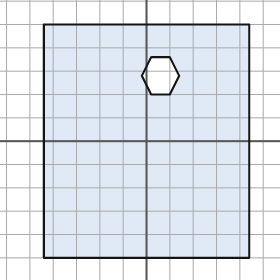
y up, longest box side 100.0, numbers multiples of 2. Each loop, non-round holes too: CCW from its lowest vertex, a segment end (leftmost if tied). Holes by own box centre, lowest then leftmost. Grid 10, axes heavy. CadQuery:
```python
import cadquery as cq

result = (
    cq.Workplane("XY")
    .moveTo(-44.0, -50.0)
    .lineTo(44.0, -50.0)
    .lineTo(44.0, 50.0)
    .lineTo(-44.0, 50.0)
    .close()
    .moveTo(2.0, 20.0)
    .lineTo(10.0, 20.0)
    .lineTo(14.0, 28.0)
    .lineTo(10.0, 36.0)
    .lineTo(2.0, 36.0)
    .lineTo(-2.0, 28.0)
    .close()
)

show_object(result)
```